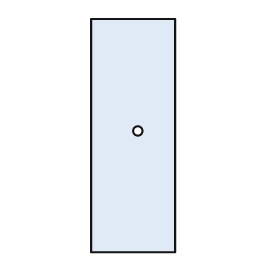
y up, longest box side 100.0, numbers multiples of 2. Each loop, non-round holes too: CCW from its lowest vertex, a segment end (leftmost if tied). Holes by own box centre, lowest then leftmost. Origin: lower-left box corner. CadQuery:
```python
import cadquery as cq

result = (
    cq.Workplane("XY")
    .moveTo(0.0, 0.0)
    .lineTo(36.0, 0.0)
    .lineTo(36.0, 100.0)
    .lineTo(0.0, 100.0)
    .close()
    .moveTo(20.0, 52.0)
    .circle(2.0)
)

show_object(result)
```